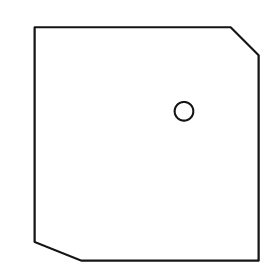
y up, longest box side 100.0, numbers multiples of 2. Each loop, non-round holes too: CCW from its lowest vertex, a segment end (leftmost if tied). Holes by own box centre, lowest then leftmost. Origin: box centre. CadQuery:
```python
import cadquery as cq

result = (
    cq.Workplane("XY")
    .moveTo(-28.0, -50.0)
    .lineTo(48.0, -50.0)
    .lineTo(48.0, 38.0)
    .lineTo(36.0, 50.0)
    .lineTo(-48.0, 50.0)
    .lineTo(-48.0, -42.0)
    .close()
    .moveTo(16.0, 14.0)
    .circle(4.0)
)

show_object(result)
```